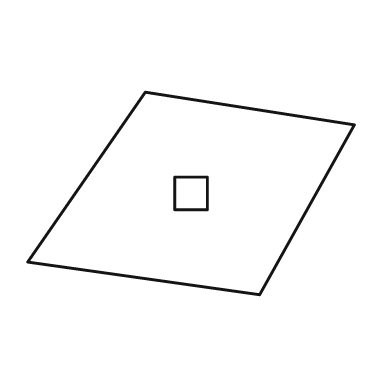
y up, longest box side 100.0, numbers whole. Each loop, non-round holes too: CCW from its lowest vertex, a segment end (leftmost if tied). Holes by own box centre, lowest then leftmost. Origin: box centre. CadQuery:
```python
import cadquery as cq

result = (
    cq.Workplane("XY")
    .moveTo(21.0, -31.0)
    .lineTo(50.0, 21.0)
    .lineTo(-14.0, 31.0)
    .lineTo(-50.0, -21.0)
    .close()
    .moveTo(-5.0, -5.0)
    .lineTo(5.0, -5.0)
    .lineTo(5.0, 5.0)
    .lineTo(-5.0, 5.0)
    .close()
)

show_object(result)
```